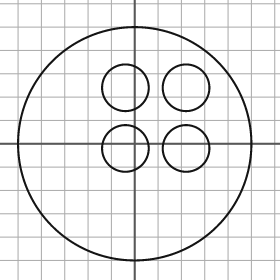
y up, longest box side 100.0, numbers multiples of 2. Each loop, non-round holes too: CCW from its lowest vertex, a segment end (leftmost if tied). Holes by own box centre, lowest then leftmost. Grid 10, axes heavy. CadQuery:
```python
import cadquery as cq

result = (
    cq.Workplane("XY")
    .moveTo(0.0, 0.0)
    .circle(50.0)
    .moveTo(-4.0, -2.0)
    .circle(10.0)
    .moveTo(22.0, -2.0)
    .circle(10.0)
    .moveTo(-4.0, 24.0)
    .circle(10.0)
    .moveTo(22.0, 24.0)
    .circle(10.0)
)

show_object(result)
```